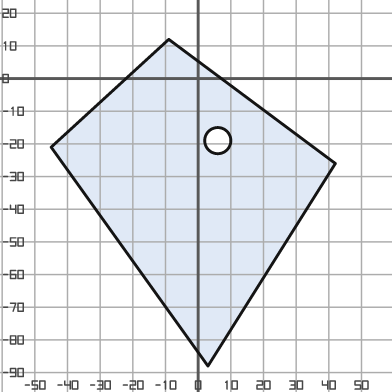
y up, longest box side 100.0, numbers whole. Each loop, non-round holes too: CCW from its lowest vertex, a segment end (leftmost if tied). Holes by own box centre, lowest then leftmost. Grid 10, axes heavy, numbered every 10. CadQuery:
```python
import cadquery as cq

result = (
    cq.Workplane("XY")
    .moveTo(3.0, -88.0)
    .lineTo(42.0, -26.0)
    .lineTo(-9.0, 12.0)
    .lineTo(-45.0, -21.0)
    .close()
    .moveTo(6.0, -19.0)
    .circle(4.0)
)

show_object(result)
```